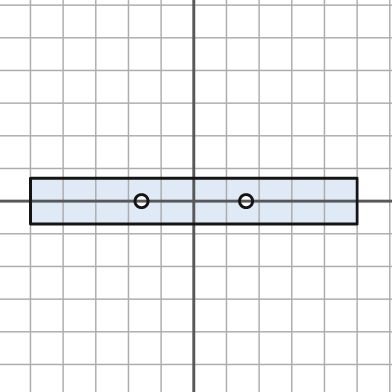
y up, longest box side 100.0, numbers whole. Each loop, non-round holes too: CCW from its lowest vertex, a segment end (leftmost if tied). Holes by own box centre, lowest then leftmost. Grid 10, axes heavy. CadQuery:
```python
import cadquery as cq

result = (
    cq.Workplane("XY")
    .moveTo(-50.0, -7.0)
    .lineTo(50.0, -7.0)
    .lineTo(50.0, 7.0)
    .lineTo(-50.0, 7.0)
    .close()
    .moveTo(-16.0, 0.0)
    .circle(2.0)
    .moveTo(16.0, 0.0)
    .circle(2.0)
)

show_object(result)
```